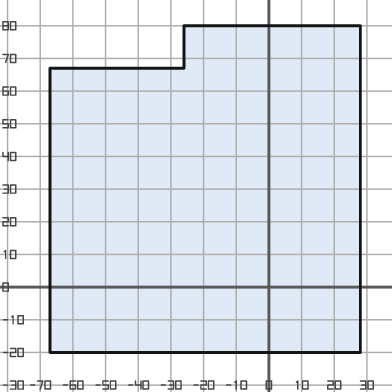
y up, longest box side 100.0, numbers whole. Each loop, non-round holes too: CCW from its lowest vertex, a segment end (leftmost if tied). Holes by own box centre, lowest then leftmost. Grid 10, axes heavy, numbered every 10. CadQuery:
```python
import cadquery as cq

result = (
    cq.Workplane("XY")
    .moveTo(-67.0, -20.0)
    .lineTo(28.0, -20.0)
    .lineTo(28.0, 80.0)
    .lineTo(-26.0, 80.0)
    .lineTo(-26.0, 67.0)
    .lineTo(-67.0, 67.0)
    .close()
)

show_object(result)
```